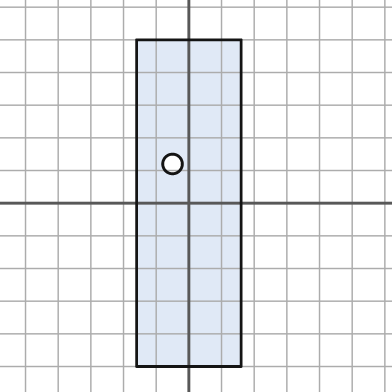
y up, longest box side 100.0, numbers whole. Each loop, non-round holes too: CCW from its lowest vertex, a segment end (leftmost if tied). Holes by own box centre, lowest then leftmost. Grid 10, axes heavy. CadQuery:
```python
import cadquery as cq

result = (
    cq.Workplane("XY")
    .moveTo(-16.0, -50.0)
    .lineTo(16.0, -50.0)
    .lineTo(16.0, 50.0)
    .lineTo(-16.0, 50.0)
    .close()
    .moveTo(-5.0, 12.0)
    .circle(3.0)
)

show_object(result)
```